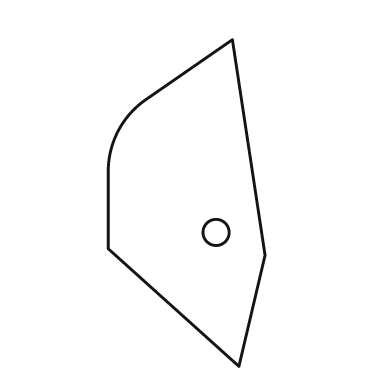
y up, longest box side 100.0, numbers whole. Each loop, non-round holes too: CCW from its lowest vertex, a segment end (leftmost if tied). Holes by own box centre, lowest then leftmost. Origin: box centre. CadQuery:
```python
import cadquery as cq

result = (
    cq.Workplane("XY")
    .moveTo(16.0, -50.0)
    .lineTo(24.0, -16.0)
    .lineTo(14.0, 50.0)
    .lineTo(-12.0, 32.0)
    .threePointArc((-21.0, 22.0), (-24.0, 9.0))
    .lineTo(-24.0, -14.0)
    .close()
    .moveTo(9.0, -9.0)
    .circle(4.0)
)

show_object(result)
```